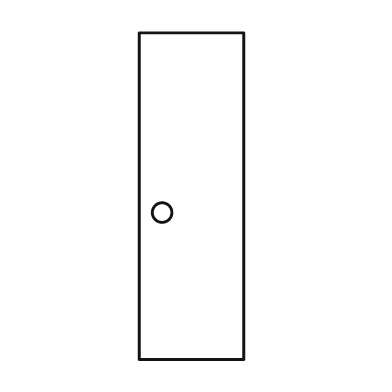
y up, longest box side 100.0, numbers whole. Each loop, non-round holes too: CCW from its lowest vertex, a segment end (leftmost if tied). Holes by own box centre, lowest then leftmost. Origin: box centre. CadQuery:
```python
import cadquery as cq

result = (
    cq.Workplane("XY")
    .moveTo(-16.0, -50.0)
    .lineTo(16.0, -50.0)
    .lineTo(16.0, 50.0)
    .lineTo(-16.0, 50.0)
    .close()
    .moveTo(-9.0, -5.0)
    .circle(3.0)
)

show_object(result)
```